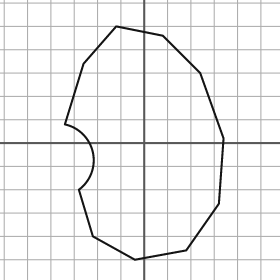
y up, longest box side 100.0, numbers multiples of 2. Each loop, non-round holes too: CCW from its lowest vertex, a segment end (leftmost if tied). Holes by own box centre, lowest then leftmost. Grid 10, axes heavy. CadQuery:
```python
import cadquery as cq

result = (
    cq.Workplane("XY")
    .moveTo(-4.0, -50.0)
    .lineTo(18.0, -46.0)
    .lineTo(32.0, -26.0)
    .lineTo(34.0, 2.0)
    .lineTo(24.0, 30.0)
    .lineTo(8.0, 46.0)
    .lineTo(-12.0, 50.0)
    .lineTo(-26.0, 34.0)
    .lineTo(-34.0, 8.0)
    .threePointArc((-22.0, -4.0), (-28.0, -20.0))
    .lineTo(-22.0, -40.0)
    .close()
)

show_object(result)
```